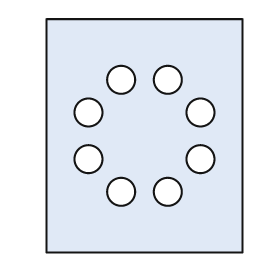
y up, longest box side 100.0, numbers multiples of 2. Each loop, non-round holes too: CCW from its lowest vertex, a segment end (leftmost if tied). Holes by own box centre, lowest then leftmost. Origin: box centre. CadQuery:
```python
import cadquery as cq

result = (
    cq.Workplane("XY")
    .moveTo(-42.0, -50.0)
    .lineTo(42.0, -50.0)
    .lineTo(42.0, 50.0)
    .lineTo(-42.0, 50.0)
    .close()
    .moveTo(-10.0, -24.0)
    .circle(6.0)
    .moveTo(10.0, -24.0)
    .circle(6.0)
    .moveTo(-24.0, -10.0)
    .circle(6.0)
    .moveTo(24.0, -10.0)
    .circle(6.0)
    .moveTo(-24.0, 10.0)
    .circle(6.0)
    .moveTo(24.0, 10.0)
    .circle(6.0)
    .moveTo(-10.0, 24.0)
    .circle(6.0)
    .moveTo(10.0, 24.0)
    .circle(6.0)
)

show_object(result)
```